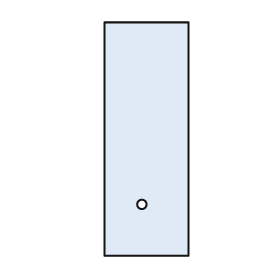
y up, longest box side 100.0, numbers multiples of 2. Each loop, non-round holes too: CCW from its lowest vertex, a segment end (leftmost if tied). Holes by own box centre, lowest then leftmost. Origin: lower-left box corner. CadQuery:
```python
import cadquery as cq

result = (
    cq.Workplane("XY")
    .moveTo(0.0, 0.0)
    .lineTo(36.0, 0.0)
    .lineTo(36.0, 100.0)
    .lineTo(0.0, 100.0)
    .close()
    .moveTo(16.0, 22.0)
    .circle(2.0)
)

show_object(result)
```